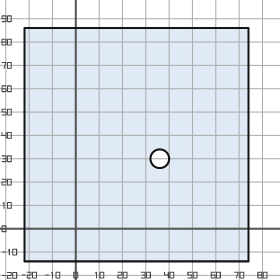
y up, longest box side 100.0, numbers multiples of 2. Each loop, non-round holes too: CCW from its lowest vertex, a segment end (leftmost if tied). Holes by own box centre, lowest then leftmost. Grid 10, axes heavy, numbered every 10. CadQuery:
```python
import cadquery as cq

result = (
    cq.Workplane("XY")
    .moveTo(-22.0, -14.0)
    .lineTo(74.0, -14.0)
    .lineTo(74.0, 86.0)
    .lineTo(-22.0, 86.0)
    .close()
    .moveTo(36.0, 30.0)
    .circle(4.0)
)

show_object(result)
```